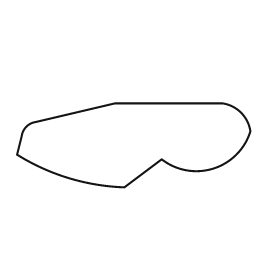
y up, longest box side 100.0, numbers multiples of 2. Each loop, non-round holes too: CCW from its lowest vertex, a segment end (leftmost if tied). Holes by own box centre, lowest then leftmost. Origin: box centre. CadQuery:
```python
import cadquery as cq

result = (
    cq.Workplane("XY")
    .moveTo(-4.0, -18.0)
    .lineTo(12.0, -6.0)
    .threePointArc((34.0, -10.0), (50.0, 6.0))
    .threePointArc((46.0, 14.0), (38.0, 18.0))
    .lineTo(-8.0, 18.0)
    .lineTo(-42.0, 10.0)
    .threePointArc((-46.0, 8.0), (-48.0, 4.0))
    .lineTo(-50.0, -4.0)
    .threePointArc((-28.0, -14.0), (-4.0, -18.0))
    .close()
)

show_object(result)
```